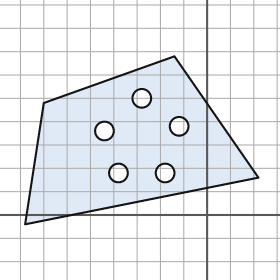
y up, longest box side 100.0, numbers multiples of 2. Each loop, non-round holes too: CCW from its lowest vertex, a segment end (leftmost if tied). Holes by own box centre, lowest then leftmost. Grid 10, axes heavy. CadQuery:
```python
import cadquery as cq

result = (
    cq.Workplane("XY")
    .moveTo(-78.0, -4.0)
    .lineTo(22.0, 16.0)
    .lineTo(-14.0, 68.0)
    .lineTo(-70.0, 48.0)
    .close()
    .moveTo(-38.0, 18.0)
    .circle(4.0)
    .moveTo(-18.0, 18.0)
    .circle(4.0)
    .moveTo(-44.0, 36.0)
    .circle(4.0)
    .moveTo(-12.0, 38.0)
    .circle(4.0)
    .moveTo(-28.0, 50.0)
    .circle(4.0)
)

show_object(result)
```